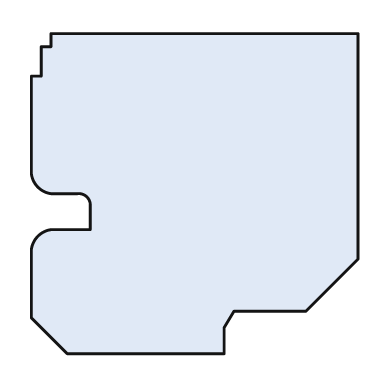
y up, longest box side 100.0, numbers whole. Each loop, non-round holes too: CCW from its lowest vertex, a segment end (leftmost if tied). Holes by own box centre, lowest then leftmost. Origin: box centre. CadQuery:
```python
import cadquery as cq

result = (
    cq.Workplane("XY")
    .moveTo(-39.0, -49.0)
    .lineTo(9.0, -49.0)
    .lineTo(9.0, -41.0)
    .lineTo(12.0, -36.0)
    .lineTo(34.0, -36.0)
    .lineTo(50.0, -20.0)
    .lineTo(50.0, 49.0)
    .lineTo(-44.0, 49.0)
    .lineTo(-44.0, 45.0)
    .lineTo(-47.0, 45.0)
    .lineTo(-47.0, 36.0)
    .lineTo(-50.0, 36.0)
    .lineTo(-50.0, 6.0)
    .threePointArc((-48.0, 2.0), (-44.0, 0.0))
    .lineTo(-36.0, 0.0)
    .threePointArc((-33.0, -1.0), (-32.0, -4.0))
    .lineTo(-32.0, -11.0)
    .lineTo(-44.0, -11.0)
    .threePointArc((-48.0, -13.0), (-50.0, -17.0))
    .lineTo(-50.0, -38.0)
    .close()
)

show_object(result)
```